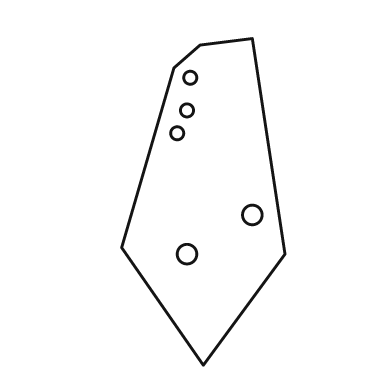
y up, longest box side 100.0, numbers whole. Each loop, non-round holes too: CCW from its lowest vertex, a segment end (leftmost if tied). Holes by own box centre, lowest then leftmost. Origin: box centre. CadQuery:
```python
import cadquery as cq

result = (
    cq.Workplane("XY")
    .moveTo(0.0, -50.0)
    .lineTo(25.0, -16.0)
    .lineTo(15.0, 50.0)
    .lineTo(-1.0, 48.0)
    .lineTo(-9.0, 41.0)
    .lineTo(-25.0, -14.0)
    .close()
    .moveTo(-5.0, -16.0)
    .circle(3.0)
    .moveTo(15.0, -4.0)
    .circle(3.0)
    .moveTo(-8.0, 21.0)
    .circle(2.0)
    .moveTo(-5.0, 28.0)
    .circle(2.0)
    .moveTo(-4.0, 38.0)
    .circle(2.0)
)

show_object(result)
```